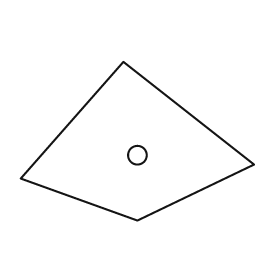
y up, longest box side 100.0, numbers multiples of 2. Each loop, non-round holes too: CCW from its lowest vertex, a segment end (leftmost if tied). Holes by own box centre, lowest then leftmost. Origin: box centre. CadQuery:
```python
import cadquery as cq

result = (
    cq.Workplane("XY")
    .moveTo(0.0, -34.0)
    .lineTo(50.0, -10.0)
    .lineTo(-6.0, 34.0)
    .lineTo(-50.0, -16.0)
    .close()
    .moveTo(0.0, -6.0)
    .circle(4.0)
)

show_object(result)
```